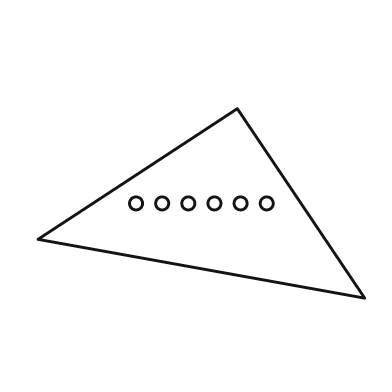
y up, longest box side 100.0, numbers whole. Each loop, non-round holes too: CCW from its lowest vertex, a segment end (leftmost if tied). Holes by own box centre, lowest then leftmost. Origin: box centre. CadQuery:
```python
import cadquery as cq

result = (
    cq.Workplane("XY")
    .moveTo(50.0, -29.0)
    .lineTo(11.0, 29.0)
    .lineTo(-50.0, -11.0)
    .close()
    .moveTo(-20.0, 0.0)
    .circle(2.0)
    .moveTo(-12.0, 0.0)
    .circle(2.0)
    .moveTo(-4.0, 0.0)
    .circle(2.0)
    .moveTo(4.0, 0.0)
    .circle(2.0)
    .moveTo(12.0, 0.0)
    .circle(2.0)
    .moveTo(20.0, 0.0)
    .circle(2.0)
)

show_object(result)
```